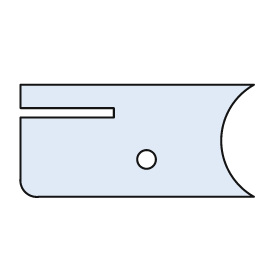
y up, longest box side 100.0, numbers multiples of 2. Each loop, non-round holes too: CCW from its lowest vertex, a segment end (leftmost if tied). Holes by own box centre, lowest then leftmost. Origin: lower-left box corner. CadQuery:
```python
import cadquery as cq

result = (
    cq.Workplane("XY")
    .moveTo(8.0, 0.0)
    .lineTo(100.0, 0.0)
    .threePointArc((86.0, 24.0), (100.0, 48.0))
    .lineTo(0.0, 48.0)
    .lineTo(0.0, 38.0)
    .lineTo(40.0, 38.0)
    .lineTo(40.0, 34.0)
    .lineTo(0.0, 34.0)
    .lineTo(0.0, 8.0)
    .threePointArc((2.0, 2.0), (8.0, 0.0))
    .close()
    .moveTo(54.0, 16.0)
    .circle(4.0)
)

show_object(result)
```